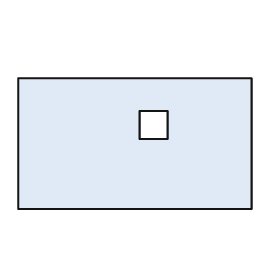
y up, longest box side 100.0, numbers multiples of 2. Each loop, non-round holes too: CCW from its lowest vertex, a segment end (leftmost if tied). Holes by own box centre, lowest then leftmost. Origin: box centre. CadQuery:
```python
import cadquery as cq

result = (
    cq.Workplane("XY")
    .moveTo(-50.0, -28.0)
    .lineTo(50.0, -28.0)
    .lineTo(50.0, 28.0)
    .lineTo(-50.0, 28.0)
    .close()
    .moveTo(2.0, 2.0)
    .lineTo(14.0, 2.0)
    .lineTo(14.0, 14.0)
    .lineTo(2.0, 14.0)
    .close()
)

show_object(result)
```